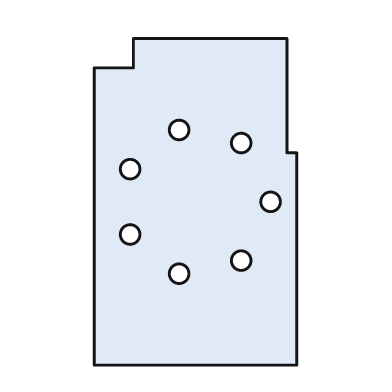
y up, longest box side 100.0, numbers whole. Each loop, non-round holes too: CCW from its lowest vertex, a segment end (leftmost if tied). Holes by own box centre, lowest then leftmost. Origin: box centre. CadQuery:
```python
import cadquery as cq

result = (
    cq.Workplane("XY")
    .moveTo(-31.0, -50.0)
    .lineTo(31.0, -50.0)
    .lineTo(31.0, 15.0)
    .lineTo(28.0, 15.0)
    .lineTo(28.0, 50.0)
    .lineTo(-19.0, 50.0)
    .lineTo(-19.0, 41.0)
    .lineTo(-31.0, 41.0)
    .close()
    .moveTo(-5.0, -22.0)
    .circle(3.0)
    .moveTo(14.0, -18.0)
    .circle(3.0)
    .moveTo(-20.0, -10.0)
    .circle(3.0)
    .moveTo(23.0, 0.0)
    .circle(3.0)
    .moveTo(-20.0, 10.0)
    .circle(3.0)
    .moveTo(14.0, 18.0)
    .circle(3.0)
    .moveTo(-5.0, 22.0)
    .circle(3.0)
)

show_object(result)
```